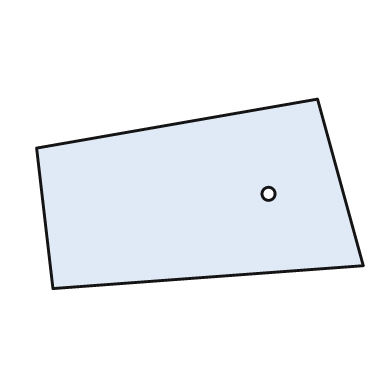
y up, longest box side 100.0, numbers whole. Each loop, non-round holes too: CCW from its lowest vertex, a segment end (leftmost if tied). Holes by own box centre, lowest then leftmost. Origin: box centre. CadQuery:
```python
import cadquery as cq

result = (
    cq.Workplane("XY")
    .moveTo(-45.0, -29.0)
    .lineTo(50.0, -22.0)
    .lineTo(36.0, 29.0)
    .lineTo(-50.0, 14.0)
    .close()
    .moveTo(21.0, 0.0)
    .circle(2.0)
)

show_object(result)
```